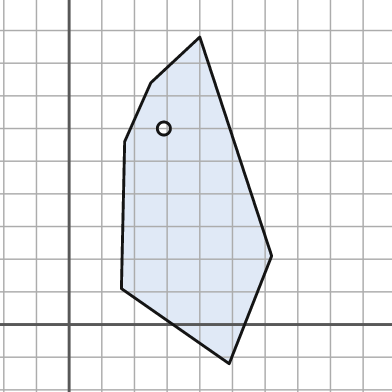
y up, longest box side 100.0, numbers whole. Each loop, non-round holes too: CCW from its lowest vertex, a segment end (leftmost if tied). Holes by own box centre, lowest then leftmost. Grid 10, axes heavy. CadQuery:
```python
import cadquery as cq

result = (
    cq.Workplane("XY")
    .moveTo(49.0, -12.0)
    .lineTo(62.0, 21.0)
    .lineTo(40.0, 88.0)
    .lineTo(25.0, 74.0)
    .lineTo(17.0, 56.0)
    .lineTo(16.0, 11.0)
    .close()
    .moveTo(29.0, 60.0)
    .circle(2.0)
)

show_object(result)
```